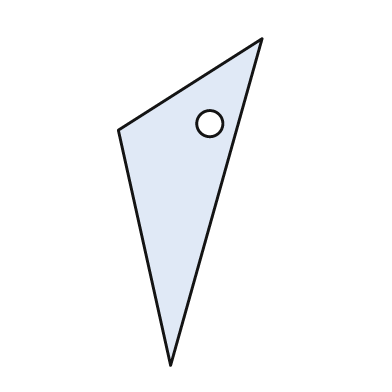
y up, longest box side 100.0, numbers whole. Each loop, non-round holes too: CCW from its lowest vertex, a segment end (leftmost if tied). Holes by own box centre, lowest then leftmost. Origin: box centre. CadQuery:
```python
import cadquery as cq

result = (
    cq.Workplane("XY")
    .moveTo(-6.0, -50.0)
    .lineTo(22.0, 50.0)
    .lineTo(-22.0, 22.0)
    .close()
    .moveTo(6.0, 24.0)
    .circle(4.0)
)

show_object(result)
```